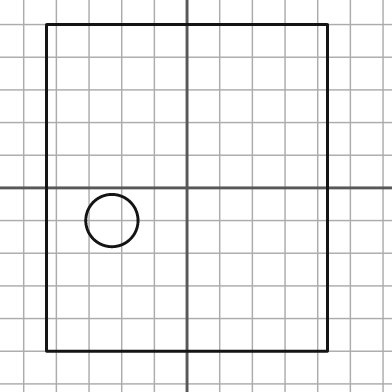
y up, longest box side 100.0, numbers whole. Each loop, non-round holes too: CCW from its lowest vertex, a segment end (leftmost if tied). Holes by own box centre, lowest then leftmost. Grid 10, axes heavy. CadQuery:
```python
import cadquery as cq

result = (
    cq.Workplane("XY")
    .moveTo(-43.0, -50.0)
    .lineTo(43.0, -50.0)
    .lineTo(43.0, 50.0)
    .lineTo(-43.0, 50.0)
    .close()
    .moveTo(-23.0, -10.0)
    .circle(8.0)
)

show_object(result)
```